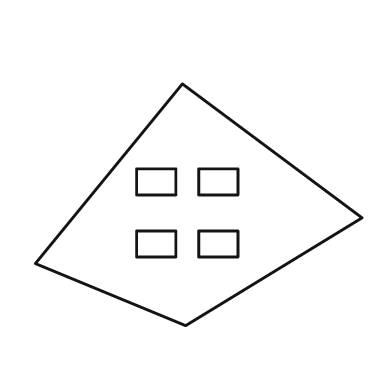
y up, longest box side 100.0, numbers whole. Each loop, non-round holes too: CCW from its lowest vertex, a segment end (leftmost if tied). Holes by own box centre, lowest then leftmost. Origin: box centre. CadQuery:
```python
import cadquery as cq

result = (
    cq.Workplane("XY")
    .moveTo(-4.0, -37.0)
    .lineTo(50.0, -4.0)
    .lineTo(-5.0, 37.0)
    .lineTo(-50.0, -18.0)
    .close()
    .moveTo(-19.0, -16.0)
    .lineTo(-7.0, -16.0)
    .lineTo(-7.0, -8.0)
    .lineTo(-19.0, -8.0)
    .close()
    .moveTo(0.0, -16.0)
    .lineTo(12.0, -16.0)
    .lineTo(12.0, -8.0)
    .lineTo(0.0, -8.0)
    .close()
    .moveTo(-19.0, 3.0)
    .lineTo(-7.0, 3.0)
    .lineTo(-7.0, 11.0)
    .lineTo(-19.0, 11.0)
    .close()
    .moveTo(0.0, 3.0)
    .lineTo(12.0, 3.0)
    .lineTo(12.0, 11.0)
    .lineTo(0.0, 11.0)
    .close()
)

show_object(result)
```